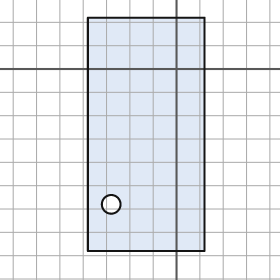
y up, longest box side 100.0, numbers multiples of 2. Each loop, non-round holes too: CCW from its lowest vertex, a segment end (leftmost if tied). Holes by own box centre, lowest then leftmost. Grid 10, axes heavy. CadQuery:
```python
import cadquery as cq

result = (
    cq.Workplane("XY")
    .moveTo(-38.0, -78.0)
    .lineTo(12.0, -78.0)
    .lineTo(12.0, 22.0)
    .lineTo(-38.0, 22.0)
    .close()
    .moveTo(-28.0, -58.0)
    .circle(4.0)
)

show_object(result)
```